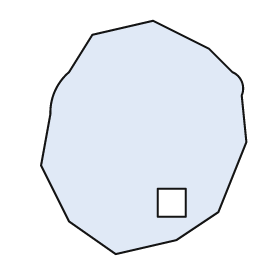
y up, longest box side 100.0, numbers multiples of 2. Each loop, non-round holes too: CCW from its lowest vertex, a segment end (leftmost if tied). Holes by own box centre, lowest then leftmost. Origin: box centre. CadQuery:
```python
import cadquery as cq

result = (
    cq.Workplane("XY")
    .moveTo(-12.0, -50.0)
    .lineTo(14.0, -44.0)
    .lineTo(32.0, -32.0)
    .lineTo(44.0, -2.0)
    .lineTo(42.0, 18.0)
    .threePointArc((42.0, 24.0), (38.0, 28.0))
    .lineTo(28.0, 38.0)
    .lineTo(4.0, 50.0)
    .lineTo(-22.0, 44.0)
    .lineTo(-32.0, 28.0)
    .threePointArc((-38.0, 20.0), (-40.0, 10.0))
    .lineTo(-44.0, -12.0)
    .lineTo(-32.0, -36.0)
    .close()
    .moveTo(6.0, -34.0)
    .lineTo(18.0, -34.0)
    .lineTo(18.0, -22.0)
    .lineTo(6.0, -22.0)
    .close()
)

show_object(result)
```